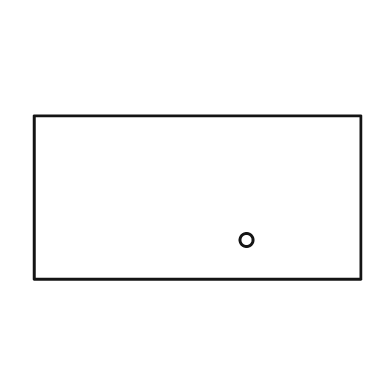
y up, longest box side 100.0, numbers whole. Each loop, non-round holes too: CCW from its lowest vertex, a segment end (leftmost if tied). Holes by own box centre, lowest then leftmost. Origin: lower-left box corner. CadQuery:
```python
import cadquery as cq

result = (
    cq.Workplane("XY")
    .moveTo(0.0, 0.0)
    .lineTo(100.0, 0.0)
    .lineTo(100.0, 50.0)
    .lineTo(0.0, 50.0)
    .close()
    .moveTo(65.0, 12.0)
    .circle(2.0)
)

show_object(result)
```